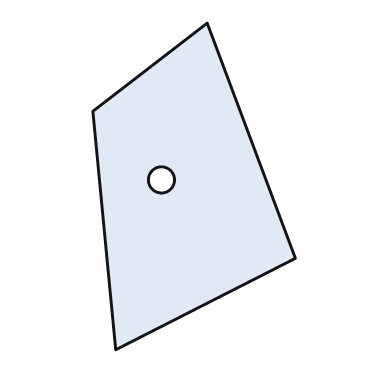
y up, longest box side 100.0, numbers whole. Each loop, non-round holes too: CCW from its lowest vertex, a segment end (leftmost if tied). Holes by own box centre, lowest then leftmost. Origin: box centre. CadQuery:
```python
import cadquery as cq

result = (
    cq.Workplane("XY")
    .moveTo(-24.0, -50.0)
    .lineTo(31.0, -22.0)
    .lineTo(4.0, 50.0)
    .lineTo(-31.0, 23.0)
    .close()
    .moveTo(-10.0, 2.0)
    .circle(4.0)
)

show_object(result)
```